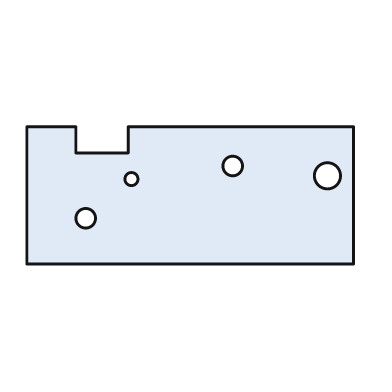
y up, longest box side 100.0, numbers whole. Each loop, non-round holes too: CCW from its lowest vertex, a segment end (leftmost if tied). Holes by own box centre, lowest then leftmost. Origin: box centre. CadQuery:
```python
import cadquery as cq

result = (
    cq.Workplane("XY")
    .moveTo(-50.0, -21.0)
    .lineTo(50.0, -21.0)
    .lineTo(50.0, 21.0)
    .lineTo(-19.0, 21.0)
    .lineTo(-19.0, 13.0)
    .lineTo(-35.0, 13.0)
    .lineTo(-35.0, 21.0)
    .lineTo(-50.0, 21.0)
    .close()
    .moveTo(-32.0, -7.0)
    .circle(3.0)
    .moveTo(-18.0, 5.0)
    .circle(2.0)
    .moveTo(42.0, 6.0)
    .circle(4.0)
    .moveTo(13.0, 9.0)
    .circle(3.0)
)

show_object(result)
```